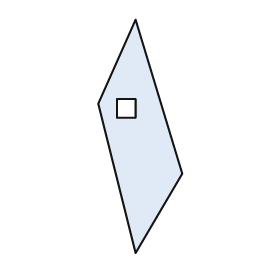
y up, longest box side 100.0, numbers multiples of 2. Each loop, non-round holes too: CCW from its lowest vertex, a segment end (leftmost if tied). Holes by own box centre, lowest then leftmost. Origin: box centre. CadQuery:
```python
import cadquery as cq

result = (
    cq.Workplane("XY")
    .moveTo(-2.0, -50.0)
    .lineTo(18.0, -16.0)
    .lineTo(-2.0, 50.0)
    .lineTo(-18.0, 14.0)
    .close()
    .moveTo(-10.0, 8.0)
    .lineTo(-2.0, 8.0)
    .lineTo(-2.0, 16.0)
    .lineTo(-10.0, 16.0)
    .close()
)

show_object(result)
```